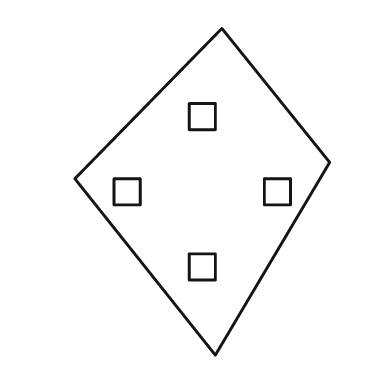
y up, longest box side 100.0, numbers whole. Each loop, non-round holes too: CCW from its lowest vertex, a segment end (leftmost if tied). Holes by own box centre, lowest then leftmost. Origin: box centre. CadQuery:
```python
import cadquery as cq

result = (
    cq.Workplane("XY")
    .moveTo(4.0, -50.0)
    .lineTo(39.0, 9.0)
    .lineTo(6.0, 50.0)
    .lineTo(-39.0, 4.0)
    .close()
    .moveTo(-4.0, -27.0)
    .lineTo(4.0, -27.0)
    .lineTo(4.0, -19.0)
    .lineTo(-4.0, -19.0)
    .close()
    .moveTo(-27.0, -4.0)
    .lineTo(-19.0, -4.0)
    .lineTo(-19.0, 4.0)
    .lineTo(-27.0, 4.0)
    .close()
    .moveTo(19.0, -4.0)
    .lineTo(27.0, -4.0)
    .lineTo(27.0, 4.0)
    .lineTo(19.0, 4.0)
    .close()
    .moveTo(-4.0, 19.0)
    .lineTo(4.0, 19.0)
    .lineTo(4.0, 27.0)
    .lineTo(-4.0, 27.0)
    .close()
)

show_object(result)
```